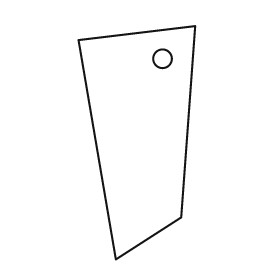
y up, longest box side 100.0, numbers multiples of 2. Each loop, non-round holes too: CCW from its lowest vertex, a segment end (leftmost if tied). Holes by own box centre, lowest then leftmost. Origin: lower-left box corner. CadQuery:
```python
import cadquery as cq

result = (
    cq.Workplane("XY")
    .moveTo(16.0, 0.0)
    .lineTo(44.0, 18.0)
    .lineTo(50.0, 100.0)
    .lineTo(0.0, 94.0)
    .close()
    .moveTo(36.0, 86.0)
    .circle(4.0)
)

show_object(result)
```